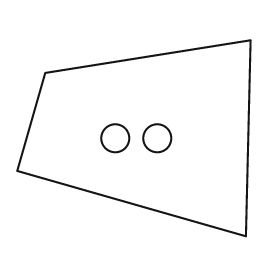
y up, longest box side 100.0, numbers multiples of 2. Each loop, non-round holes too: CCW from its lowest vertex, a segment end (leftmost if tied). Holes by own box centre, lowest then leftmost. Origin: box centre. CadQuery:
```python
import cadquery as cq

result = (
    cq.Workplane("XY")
    .moveTo(48.0, -42.0)
    .lineTo(50.0, 42.0)
    .lineTo(-38.0, 28.0)
    .lineTo(-50.0, -14.0)
    .close()
    .moveTo(-8.0, 0.0)
    .circle(6.0)
    .moveTo(10.0, 0.0)
    .circle(6.0)
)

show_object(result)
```